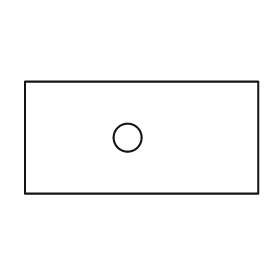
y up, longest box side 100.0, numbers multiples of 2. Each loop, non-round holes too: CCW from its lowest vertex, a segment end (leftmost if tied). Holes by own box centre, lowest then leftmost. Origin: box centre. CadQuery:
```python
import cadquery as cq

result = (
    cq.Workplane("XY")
    .moveTo(-50.0, -24.0)
    .lineTo(50.0, -24.0)
    .lineTo(50.0, 24.0)
    .lineTo(-50.0, 24.0)
    .close()
    .moveTo(-6.0, 0.0)
    .circle(6.0)
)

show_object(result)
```